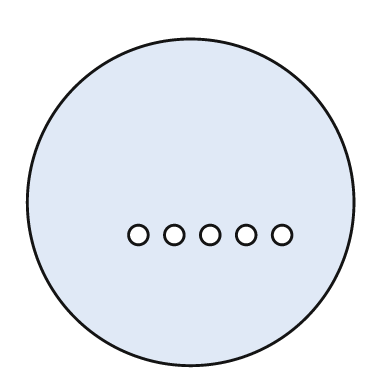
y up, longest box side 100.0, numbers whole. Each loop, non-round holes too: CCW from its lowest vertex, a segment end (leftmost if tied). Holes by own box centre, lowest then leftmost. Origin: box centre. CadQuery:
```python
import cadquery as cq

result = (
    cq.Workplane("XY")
    .moveTo(0.0, 0.0)
    .circle(50.0)
    .moveTo(-16.0, -10.0)
    .circle(3.0)
    .moveTo(-5.0, -10.0)
    .circle(3.0)
    .moveTo(6.0, -10.0)
    .circle(3.0)
    .moveTo(17.0, -10.0)
    .circle(3.0)
    .moveTo(28.0, -10.0)
    .circle(3.0)
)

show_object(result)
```